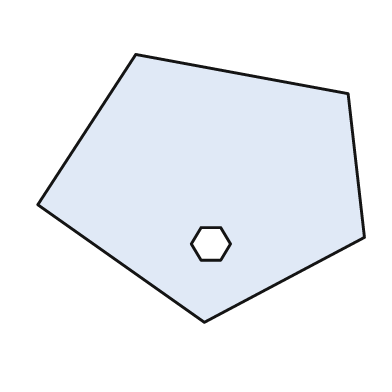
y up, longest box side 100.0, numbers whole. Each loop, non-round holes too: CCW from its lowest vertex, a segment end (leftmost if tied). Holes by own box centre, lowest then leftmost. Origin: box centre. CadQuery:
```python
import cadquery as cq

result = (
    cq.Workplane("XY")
    .moveTo(1.0, -41.0)
    .lineTo(50.0, -15.0)
    .lineTo(45.0, 29.0)
    .lineTo(-20.0, 41.0)
    .lineTo(-50.0, -5.0)
    .close()
    .moveTo(0.0, -22.0)
    .lineTo(6.0, -22.0)
    .lineTo(9.0, -17.0)
    .lineTo(6.0, -12.0)
    .lineTo(0.0, -12.0)
    .lineTo(-3.0, -17.0)
    .close()
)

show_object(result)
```